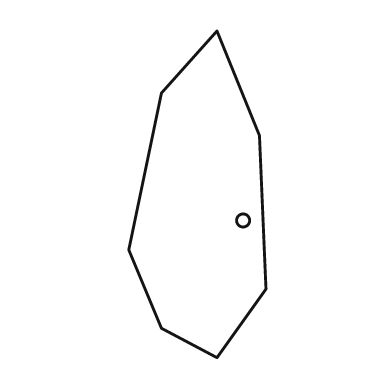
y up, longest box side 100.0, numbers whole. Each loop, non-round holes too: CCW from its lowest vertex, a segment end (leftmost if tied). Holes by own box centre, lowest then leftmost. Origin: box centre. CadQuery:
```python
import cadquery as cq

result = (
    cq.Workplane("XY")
    .moveTo(6.0, -50.0)
    .lineTo(21.0, -29.0)
    .lineTo(19.0, 18.0)
    .lineTo(6.0, 50.0)
    .lineTo(-11.0, 31.0)
    .lineTo(-21.0, -17.0)
    .lineTo(-11.0, -41.0)
    .close()
    .moveTo(14.0, -8.0)
    .circle(2.0)
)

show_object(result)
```